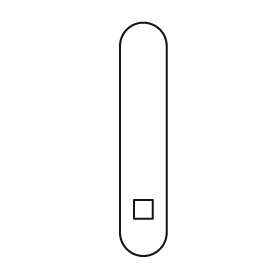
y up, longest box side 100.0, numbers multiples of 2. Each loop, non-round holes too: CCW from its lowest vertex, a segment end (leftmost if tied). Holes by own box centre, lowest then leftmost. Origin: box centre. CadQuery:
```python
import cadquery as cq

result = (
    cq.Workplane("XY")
    .moveTo(-10.0, -40.0)
    .threePointArc((0.0, -50.0), (10.0, -40.0))
    .lineTo(10.0, 40.0)
    .threePointArc((0.0, 50.0), (-10.0, 40.0))
    .close()
    .moveTo(-4.0, -34.0)
    .lineTo(4.0, -34.0)
    .lineTo(4.0, -26.0)
    .lineTo(-4.0, -26.0)
    .close()
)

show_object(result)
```